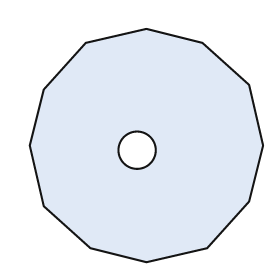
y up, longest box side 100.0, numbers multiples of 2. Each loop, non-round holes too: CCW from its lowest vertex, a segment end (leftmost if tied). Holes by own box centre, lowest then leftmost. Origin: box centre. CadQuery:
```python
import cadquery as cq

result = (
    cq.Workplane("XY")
    .moveTo(0.0, -50.0)
    .lineTo(26.0, -44.0)
    .lineTo(44.0, -24.0)
    .lineTo(50.0, 0.0)
    .lineTo(44.0, 26.0)
    .lineTo(24.0, 44.0)
    .lineTo(0.0, 50.0)
    .lineTo(-26.0, 44.0)
    .lineTo(-44.0, 24.0)
    .lineTo(-50.0, 0.0)
    .lineTo(-44.0, -26.0)
    .lineTo(-24.0, -44.0)
    .close()
    .moveTo(-4.0, -2.0)
    .circle(8.0)
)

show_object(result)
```